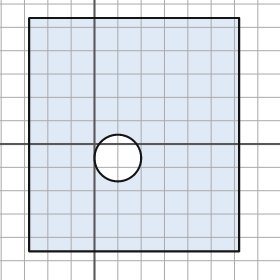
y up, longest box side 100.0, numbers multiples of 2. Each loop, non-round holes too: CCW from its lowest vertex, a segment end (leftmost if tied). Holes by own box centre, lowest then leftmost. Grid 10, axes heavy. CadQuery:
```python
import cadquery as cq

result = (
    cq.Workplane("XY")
    .moveTo(-28.0, -46.0)
    .lineTo(62.0, -46.0)
    .lineTo(62.0, 54.0)
    .lineTo(-28.0, 54.0)
    .close()
    .moveTo(10.0, -6.0)
    .circle(10.0)
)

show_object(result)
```